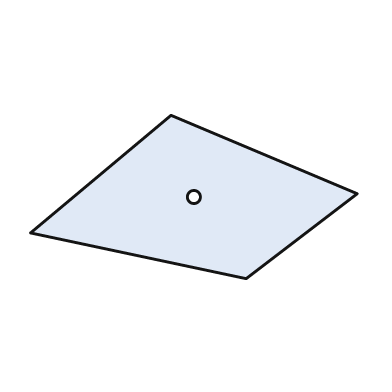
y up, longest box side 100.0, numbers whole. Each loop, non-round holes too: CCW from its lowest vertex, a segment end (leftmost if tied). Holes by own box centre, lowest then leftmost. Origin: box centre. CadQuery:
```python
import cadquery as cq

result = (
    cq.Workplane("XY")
    .moveTo(16.0, -25.0)
    .lineTo(50.0, 1.0)
    .lineTo(-7.0, 25.0)
    .lineTo(-50.0, -11.0)
    .close()
    .moveTo(0.0, 0.0)
    .circle(2.0)
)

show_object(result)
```